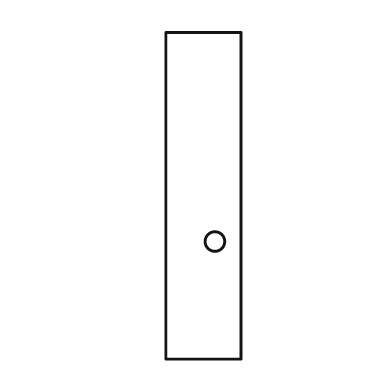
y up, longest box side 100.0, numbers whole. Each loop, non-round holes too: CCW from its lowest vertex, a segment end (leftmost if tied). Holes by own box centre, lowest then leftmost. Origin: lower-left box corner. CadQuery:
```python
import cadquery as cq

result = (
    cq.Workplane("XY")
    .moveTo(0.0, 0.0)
    .lineTo(23.0, 0.0)
    .lineTo(23.0, 100.0)
    .lineTo(0.0, 100.0)
    .close()
    .moveTo(15.0, 36.0)
    .circle(3.0)
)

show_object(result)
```